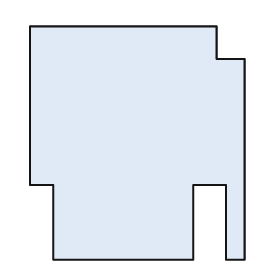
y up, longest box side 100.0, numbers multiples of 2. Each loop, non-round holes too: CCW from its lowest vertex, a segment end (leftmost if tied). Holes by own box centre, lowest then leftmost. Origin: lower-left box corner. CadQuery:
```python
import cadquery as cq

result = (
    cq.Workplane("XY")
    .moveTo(10.0, 0.0)
    .lineTo(70.0, 0.0)
    .lineTo(70.0, 32.0)
    .lineTo(84.0, 32.0)
    .lineTo(84.0, 0.0)
    .lineTo(92.0, 0.0)
    .lineTo(92.0, 86.0)
    .lineTo(80.0, 86.0)
    .lineTo(80.0, 100.0)
    .lineTo(0.0, 100.0)
    .lineTo(0.0, 32.0)
    .lineTo(10.0, 32.0)
    .close()
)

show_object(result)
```